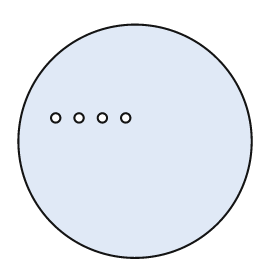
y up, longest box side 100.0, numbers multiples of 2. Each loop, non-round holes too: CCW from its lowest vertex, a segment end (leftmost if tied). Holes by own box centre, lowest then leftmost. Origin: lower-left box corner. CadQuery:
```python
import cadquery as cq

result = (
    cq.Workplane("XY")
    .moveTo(50.0, 50.0)
    .circle(50.0)
    .moveTo(16.0, 60.0)
    .circle(2.0)
    .moveTo(26.0, 60.0)
    .circle(2.0)
    .moveTo(36.0, 60.0)
    .circle(2.0)
    .moveTo(46.0, 60.0)
    .circle(2.0)
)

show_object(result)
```